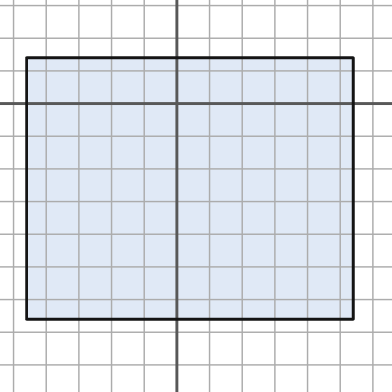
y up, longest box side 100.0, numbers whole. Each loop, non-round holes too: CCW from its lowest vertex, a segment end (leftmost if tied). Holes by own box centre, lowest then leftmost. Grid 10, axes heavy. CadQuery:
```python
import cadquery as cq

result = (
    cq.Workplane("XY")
    .moveTo(-46.0, -66.0)
    .lineTo(54.0, -66.0)
    .lineTo(54.0, 14.0)
    .lineTo(-46.0, 14.0)
    .close()
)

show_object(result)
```